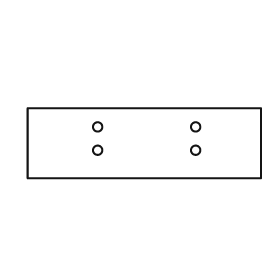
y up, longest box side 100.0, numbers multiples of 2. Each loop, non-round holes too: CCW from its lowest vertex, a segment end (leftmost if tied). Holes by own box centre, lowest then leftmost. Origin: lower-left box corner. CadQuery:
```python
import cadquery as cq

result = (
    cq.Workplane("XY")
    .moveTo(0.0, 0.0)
    .lineTo(100.0, 0.0)
    .lineTo(100.0, 30.0)
    .lineTo(0.0, 30.0)
    .close()
    .moveTo(30.0, 12.0)
    .circle(2.0)
    .moveTo(72.0, 12.0)
    .circle(2.0)
    .moveTo(30.0, 22.0)
    .circle(2.0)
    .moveTo(72.0, 22.0)
    .circle(2.0)
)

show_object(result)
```